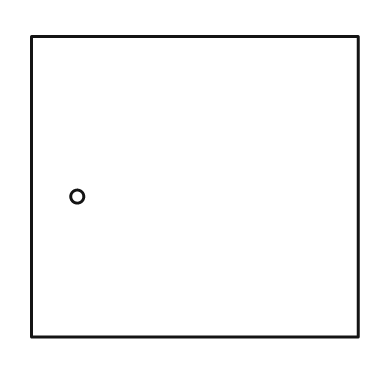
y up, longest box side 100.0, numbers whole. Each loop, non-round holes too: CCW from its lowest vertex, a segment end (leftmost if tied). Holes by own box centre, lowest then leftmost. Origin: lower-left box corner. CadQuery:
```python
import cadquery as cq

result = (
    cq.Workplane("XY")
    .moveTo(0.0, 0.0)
    .lineTo(100.0, 0.0)
    .lineTo(100.0, 92.0)
    .lineTo(0.0, 92.0)
    .close()
    .moveTo(14.0, 43.0)
    .circle(2.0)
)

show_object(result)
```